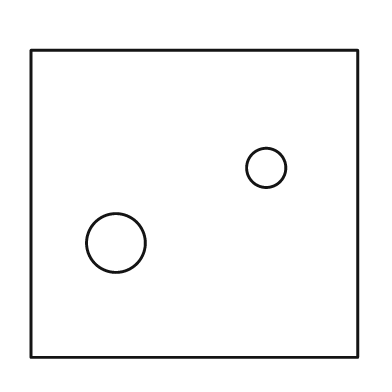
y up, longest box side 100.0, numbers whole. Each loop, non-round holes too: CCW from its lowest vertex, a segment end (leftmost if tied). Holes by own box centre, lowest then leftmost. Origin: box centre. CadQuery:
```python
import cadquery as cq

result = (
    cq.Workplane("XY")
    .moveTo(-50.0, -47.0)
    .lineTo(50.0, -47.0)
    .lineTo(50.0, 47.0)
    .lineTo(-50.0, 47.0)
    .close()
    .moveTo(-24.0, -12.0)
    .circle(9.0)
    .moveTo(22.0, 11.0)
    .circle(6.0)
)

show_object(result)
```